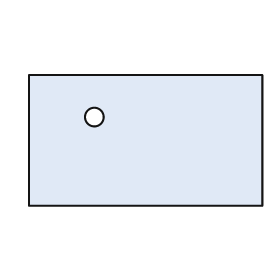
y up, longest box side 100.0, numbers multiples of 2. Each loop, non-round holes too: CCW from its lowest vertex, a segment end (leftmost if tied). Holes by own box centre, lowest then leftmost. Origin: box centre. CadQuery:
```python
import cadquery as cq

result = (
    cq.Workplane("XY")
    .moveTo(-50.0, -28.0)
    .lineTo(50.0, -28.0)
    .lineTo(50.0, 28.0)
    .lineTo(-50.0, 28.0)
    .close()
    .moveTo(-22.0, 10.0)
    .circle(4.0)
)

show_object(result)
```